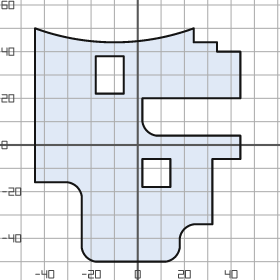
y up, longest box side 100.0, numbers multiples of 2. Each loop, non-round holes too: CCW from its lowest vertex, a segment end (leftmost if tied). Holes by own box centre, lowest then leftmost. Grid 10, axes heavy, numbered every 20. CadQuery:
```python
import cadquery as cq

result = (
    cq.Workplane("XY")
    .moveTo(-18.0, -50.0)
    .lineTo(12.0, -50.0)
    .threePointArc((16.0, -48.0), (18.0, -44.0))
    .lineTo(18.0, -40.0)
    .threePointArc((20.0, -36.0), (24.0, -34.0))
    .lineTo(32.0, -34.0)
    .lineTo(32.0, -6.0)
    .lineTo(44.0, -6.0)
    .lineTo(44.0, 4.0)
    .lineTo(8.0, 4.0)
    .threePointArc((4.0, 6.0), (2.0, 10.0))
    .lineTo(2.0, 20.0)
    .lineTo(44.0, 20.0)
    .lineTo(44.0, 40.0)
    .lineTo(34.0, 40.0)
    .lineTo(34.0, 44.0)
    .lineTo(24.0, 44.0)
    .lineTo(24.0, 50.0)
    .threePointArc((-10.0, 44.0), (-44.0, 50.0))
    .lineTo(-44.0, -16.0)
    .lineTo(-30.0, -16.0)
    .threePointArc((-26.0, -18.0), (-24.0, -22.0))
    .lineTo(-24.0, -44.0)
    .threePointArc((-22.0, -48.0), (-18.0, -50.0))
    .close()
    .moveTo(2.0, -18.0)
    .lineTo(14.0, -18.0)
    .lineTo(14.0, -6.0)
    .lineTo(2.0, -6.0)
    .close()
    .moveTo(-18.0, 22.0)
    .lineTo(-6.0, 22.0)
    .lineTo(-6.0, 38.0)
    .lineTo(-18.0, 38.0)
    .close()
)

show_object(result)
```